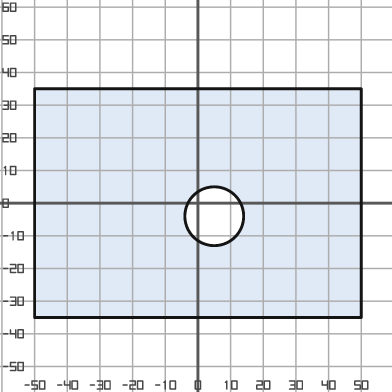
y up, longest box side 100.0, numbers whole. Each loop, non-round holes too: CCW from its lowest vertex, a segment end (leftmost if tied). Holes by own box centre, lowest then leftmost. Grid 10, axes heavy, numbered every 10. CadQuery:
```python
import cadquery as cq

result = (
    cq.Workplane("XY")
    .moveTo(-50.0, -35.0)
    .lineTo(50.0, -35.0)
    .lineTo(50.0, 35.0)
    .lineTo(-50.0, 35.0)
    .close()
    .moveTo(5.0, -4.0)
    .circle(9.0)
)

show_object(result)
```